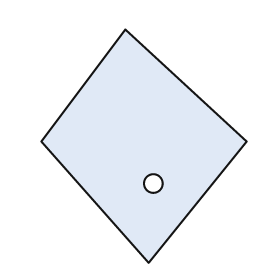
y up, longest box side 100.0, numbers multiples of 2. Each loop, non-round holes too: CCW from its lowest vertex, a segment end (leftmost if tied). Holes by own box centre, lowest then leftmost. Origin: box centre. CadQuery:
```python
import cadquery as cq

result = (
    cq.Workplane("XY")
    .moveTo(2.0, -50.0)
    .lineTo(44.0, 2.0)
    .lineTo(-8.0, 50.0)
    .lineTo(-44.0, 2.0)
    .close()
    .moveTo(4.0, -16.0)
    .circle(4.0)
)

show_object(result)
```